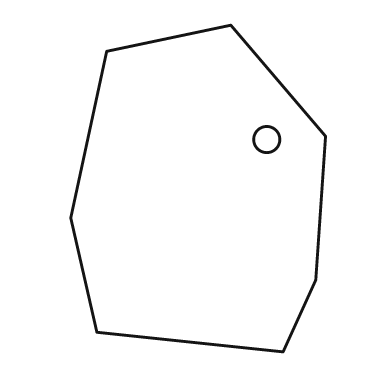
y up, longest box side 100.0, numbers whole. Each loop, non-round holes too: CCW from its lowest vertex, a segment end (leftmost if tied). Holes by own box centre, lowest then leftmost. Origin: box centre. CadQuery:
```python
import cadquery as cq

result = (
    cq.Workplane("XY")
    .moveTo(26.0, -50.0)
    .lineTo(36.0, -28.0)
    .lineTo(39.0, 16.0)
    .lineTo(10.0, 50.0)
    .lineTo(-28.0, 42.0)
    .lineTo(-39.0, -9.0)
    .lineTo(-31.0, -44.0)
    .close()
    .moveTo(21.0, 15.0)
    .circle(4.0)
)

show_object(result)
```